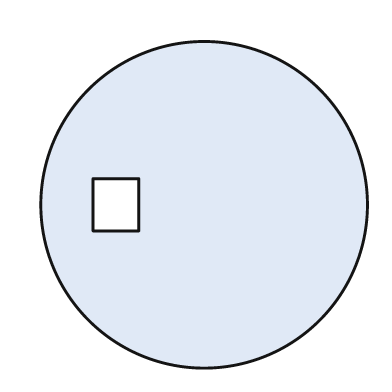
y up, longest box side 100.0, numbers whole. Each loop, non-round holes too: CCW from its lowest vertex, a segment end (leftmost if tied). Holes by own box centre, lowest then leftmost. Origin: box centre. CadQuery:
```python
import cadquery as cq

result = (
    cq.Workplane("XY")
    .moveTo(0.0, 0.0)
    .circle(50.0)
    .moveTo(-34.0, -8.0)
    .lineTo(-20.0, -8.0)
    .lineTo(-20.0, 8.0)
    .lineTo(-34.0, 8.0)
    .close()
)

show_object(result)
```